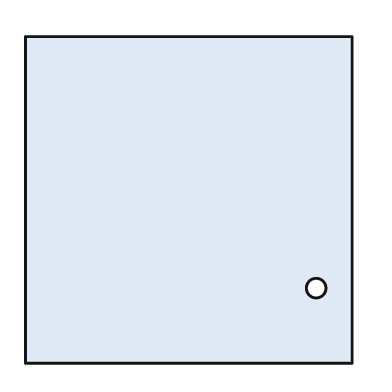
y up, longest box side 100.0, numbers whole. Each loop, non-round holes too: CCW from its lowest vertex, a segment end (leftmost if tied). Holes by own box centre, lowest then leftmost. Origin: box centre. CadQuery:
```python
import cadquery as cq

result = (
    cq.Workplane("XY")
    .moveTo(-50.0, -50.0)
    .lineTo(50.0, -50.0)
    .lineTo(50.0, 50.0)
    .lineTo(-50.0, 50.0)
    .close()
    .moveTo(39.0, -27.0)
    .circle(3.0)
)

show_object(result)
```